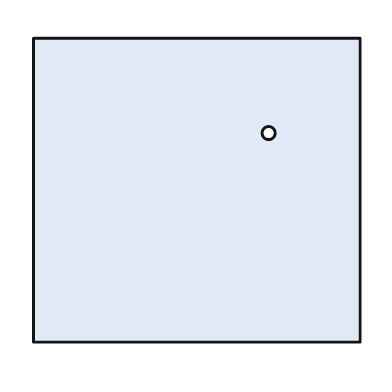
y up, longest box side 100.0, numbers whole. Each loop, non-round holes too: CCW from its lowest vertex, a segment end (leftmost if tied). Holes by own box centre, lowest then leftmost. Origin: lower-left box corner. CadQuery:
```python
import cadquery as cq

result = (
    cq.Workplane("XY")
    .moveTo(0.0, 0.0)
    .lineTo(100.0, 0.0)
    .lineTo(100.0, 93.0)
    .lineTo(0.0, 93.0)
    .close()
    .moveTo(72.0, 64.0)
    .circle(2.0)
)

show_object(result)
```